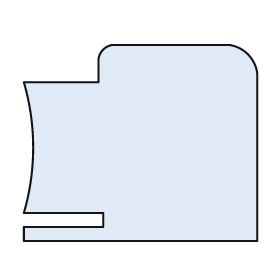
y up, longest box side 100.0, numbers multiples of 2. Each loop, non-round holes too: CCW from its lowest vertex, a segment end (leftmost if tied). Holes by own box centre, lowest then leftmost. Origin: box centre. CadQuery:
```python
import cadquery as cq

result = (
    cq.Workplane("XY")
    .moveTo(-50.0, -42.0)
    .lineTo(50.0, -42.0)
    .lineTo(50.0, 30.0)
    .threePointArc((46.0, 38.0), (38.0, 42.0))
    .lineTo(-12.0, 42.0)
    .threePointArc((-16.0, 40.0), (-18.0, 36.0))
    .lineTo(-18.0, 26.0)
    .lineTo(-50.0, 26.0)
    .threePointArc((-46.0, -2.0), (-50.0, -30.0))
    .lineTo(-16.0, -30.0)
    .lineTo(-16.0, -36.0)
    .lineTo(-50.0, -36.0)
    .close()
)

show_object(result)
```